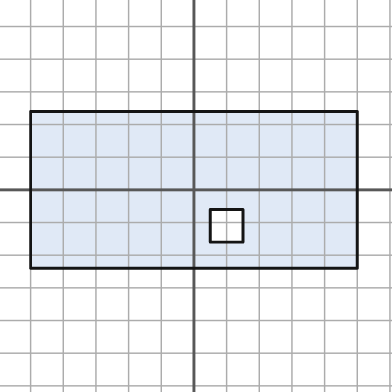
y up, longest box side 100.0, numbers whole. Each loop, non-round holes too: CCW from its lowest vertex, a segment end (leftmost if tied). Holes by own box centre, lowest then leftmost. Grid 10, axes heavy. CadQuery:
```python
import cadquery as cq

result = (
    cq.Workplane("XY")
    .moveTo(-50.0, -24.0)
    .lineTo(50.0, -24.0)
    .lineTo(50.0, 24.0)
    .lineTo(-50.0, 24.0)
    .close()
    .moveTo(5.0, -16.0)
    .lineTo(15.0, -16.0)
    .lineTo(15.0, -6.0)
    .lineTo(5.0, -6.0)
    .close()
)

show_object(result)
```